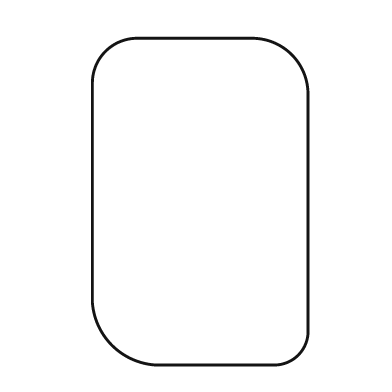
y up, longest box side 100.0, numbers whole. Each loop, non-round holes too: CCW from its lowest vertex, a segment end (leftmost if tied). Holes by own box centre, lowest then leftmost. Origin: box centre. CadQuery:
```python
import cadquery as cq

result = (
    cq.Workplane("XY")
    .moveTo(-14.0, -50.0)
    .lineTo(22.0, -50.0)
    .threePointArc((30.0, -47.0), (33.0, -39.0))
    .lineTo(33.0, 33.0)
    .threePointArc((28.0, 45.0), (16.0, 50.0))
    .lineTo(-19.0, 50.0)
    .threePointArc((-29.0, 46.0), (-33.0, 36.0))
    .lineTo(-33.0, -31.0)
    .threePointArc((-27.0, -44.0), (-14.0, -50.0))
    .close()
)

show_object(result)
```